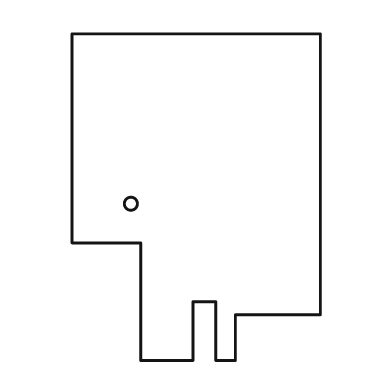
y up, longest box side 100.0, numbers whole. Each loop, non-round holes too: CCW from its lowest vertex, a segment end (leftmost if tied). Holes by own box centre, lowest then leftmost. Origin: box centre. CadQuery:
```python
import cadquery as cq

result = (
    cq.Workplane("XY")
    .moveTo(-17.0, -50.0)
    .lineTo(-1.0, -50.0)
    .lineTo(-1.0, -32.0)
    .lineTo(6.0, -32.0)
    .lineTo(6.0, -50.0)
    .lineTo(12.0, -50.0)
    .lineTo(12.0, -36.0)
    .lineTo(38.0, -36.0)
    .lineTo(38.0, 50.0)
    .lineTo(-38.0, 50.0)
    .lineTo(-38.0, -14.0)
    .lineTo(-17.0, -14.0)
    .close()
    .moveTo(-20.0, -2.0)
    .circle(2.0)
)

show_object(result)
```